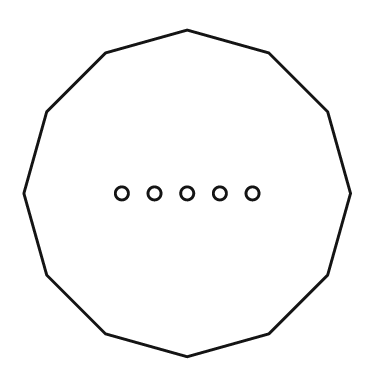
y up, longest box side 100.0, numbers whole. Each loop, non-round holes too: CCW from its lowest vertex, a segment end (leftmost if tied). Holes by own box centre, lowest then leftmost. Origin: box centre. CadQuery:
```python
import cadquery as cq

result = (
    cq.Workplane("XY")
    .moveTo(0.0, -50.0)
    .lineTo(25.0, -43.0)
    .lineTo(43.0, -25.0)
    .lineTo(50.0, 0.0)
    .lineTo(43.0, 25.0)
    .lineTo(25.0, 43.0)
    .lineTo(0.0, 50.0)
    .lineTo(-25.0, 43.0)
    .lineTo(-43.0, 25.0)
    .lineTo(-50.0, 0.0)
    .lineTo(-43.0, -25.0)
    .lineTo(-25.0, -43.0)
    .close()
    .moveTo(-20.0, 0.0)
    .circle(2.0)
    .moveTo(-10.0, 0.0)
    .circle(2.0)
    .moveTo(0.0, 0.0)
    .circle(2.0)
    .moveTo(10.0, 0.0)
    .circle(2.0)
    .moveTo(20.0, 0.0)
    .circle(2.0)
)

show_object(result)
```